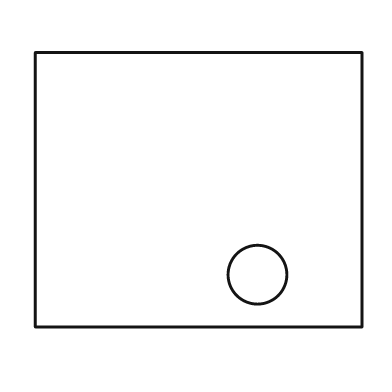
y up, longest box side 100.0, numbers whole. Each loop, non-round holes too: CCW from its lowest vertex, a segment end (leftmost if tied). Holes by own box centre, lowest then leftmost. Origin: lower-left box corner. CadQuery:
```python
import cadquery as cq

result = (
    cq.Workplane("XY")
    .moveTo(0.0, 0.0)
    .lineTo(100.0, 0.0)
    .lineTo(100.0, 84.0)
    .lineTo(0.0, 84.0)
    .close()
    .moveTo(68.0, 16.0)
    .circle(9.0)
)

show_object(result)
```